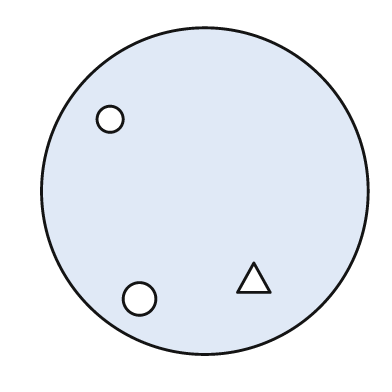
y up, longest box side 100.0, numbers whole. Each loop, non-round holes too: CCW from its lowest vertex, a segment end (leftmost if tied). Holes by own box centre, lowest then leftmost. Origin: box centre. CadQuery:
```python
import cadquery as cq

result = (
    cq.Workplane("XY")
    .moveTo(0.0, 0.0)
    .circle(50.0)
    .moveTo(-20.0, -33.0)
    .circle(5.0)
    .moveTo(10.0, -31.0)
    .lineTo(20.0, -31.0)
    .lineTo(15.0, -22.0)
    .close()
    .moveTo(-29.0, 22.0)
    .circle(4.0)
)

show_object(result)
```